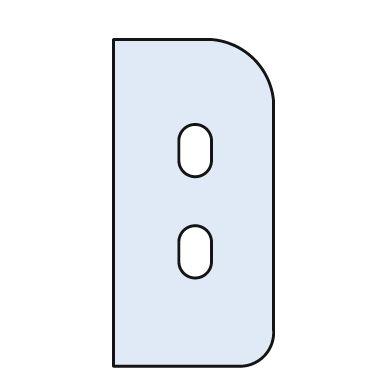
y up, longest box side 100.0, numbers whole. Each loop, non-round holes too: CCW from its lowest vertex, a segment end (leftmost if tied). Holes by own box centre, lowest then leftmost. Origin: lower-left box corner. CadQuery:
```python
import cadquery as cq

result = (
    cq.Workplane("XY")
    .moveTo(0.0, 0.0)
    .lineTo(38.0, 0.0)
    .threePointArc((46.0, 3.0), (49.0, 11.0))
    .lineTo(49.0, 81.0)
    .threePointArc((43.0, 94.0), (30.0, 100.0))
    .lineTo(0.0, 100.0)
    .close()
    .moveTo(20.0, 32.0)
    .threePointArc((25.0, 27.0), (30.0, 32.0))
    .lineTo(30.0, 38.0)
    .threePointArc((25.0, 43.0), (20.0, 38.0))
    .close()
    .moveTo(20.0, 63.0)
    .threePointArc((25.0, 58.0), (30.0, 63.0))
    .lineTo(30.0, 69.0)
    .threePointArc((25.0, 74.0), (20.0, 69.0))
    .close()
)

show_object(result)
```